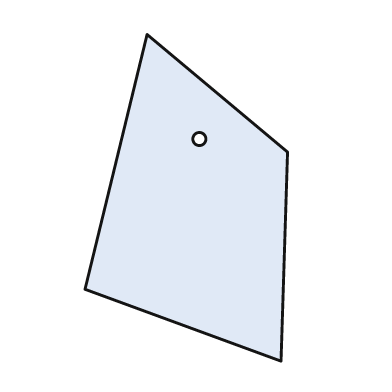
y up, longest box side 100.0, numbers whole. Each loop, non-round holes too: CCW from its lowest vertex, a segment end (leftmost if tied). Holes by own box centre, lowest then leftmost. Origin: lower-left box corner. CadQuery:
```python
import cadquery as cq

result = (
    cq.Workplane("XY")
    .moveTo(60.0, 0.0)
    .lineTo(62.0, 64.0)
    .lineTo(19.0, 100.0)
    .lineTo(0.0, 22.0)
    .close()
    .moveTo(35.0, 68.0)
    .circle(2.0)
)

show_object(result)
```